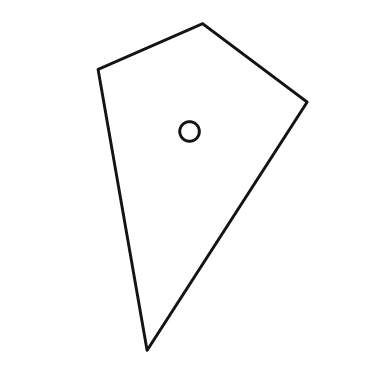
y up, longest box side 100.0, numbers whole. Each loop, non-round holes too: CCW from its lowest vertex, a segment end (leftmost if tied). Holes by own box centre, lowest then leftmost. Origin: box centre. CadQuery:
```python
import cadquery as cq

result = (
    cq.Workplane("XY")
    .moveTo(-17.0, -50.0)
    .lineTo(32.0, 26.0)
    .lineTo(0.0, 50.0)
    .lineTo(-32.0, 36.0)
    .close()
    .moveTo(-4.0, 17.0)
    .circle(3.0)
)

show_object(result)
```